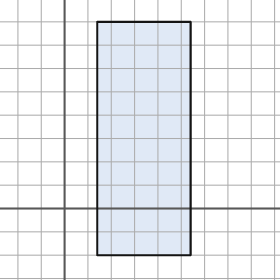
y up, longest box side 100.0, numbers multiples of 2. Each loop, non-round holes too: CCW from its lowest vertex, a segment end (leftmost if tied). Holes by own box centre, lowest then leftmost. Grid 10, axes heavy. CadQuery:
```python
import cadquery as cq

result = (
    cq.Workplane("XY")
    .moveTo(14.0, -20.0)
    .lineTo(54.0, -20.0)
    .lineTo(54.0, 80.0)
    .lineTo(14.0, 80.0)
    .close()
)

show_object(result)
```